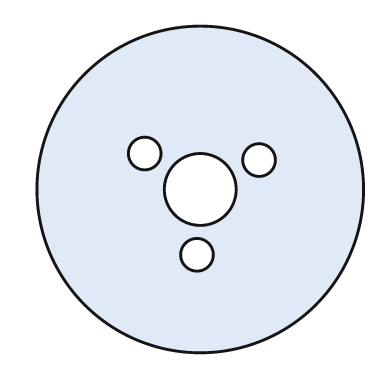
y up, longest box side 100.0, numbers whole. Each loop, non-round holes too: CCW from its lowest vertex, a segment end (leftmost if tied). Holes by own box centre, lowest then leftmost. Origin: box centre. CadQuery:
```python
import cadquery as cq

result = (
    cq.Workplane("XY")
    .moveTo(0.0, 0.0)
    .circle(50.0)
    .moveTo(-1.0, -20.0)
    .circle(5.0)
    .moveTo(0.0, 0.0)
    .circle(11.0)
    .moveTo(18.0, 9.0)
    .circle(5.0)
    .moveTo(-17.0, 11.0)
    .circle(5.0)
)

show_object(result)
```